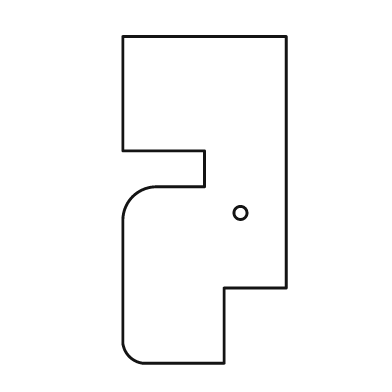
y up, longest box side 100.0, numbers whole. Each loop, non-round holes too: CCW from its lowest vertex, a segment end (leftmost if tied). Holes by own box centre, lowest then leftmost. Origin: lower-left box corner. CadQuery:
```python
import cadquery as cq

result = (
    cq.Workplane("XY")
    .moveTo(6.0, 0.0)
    .lineTo(31.0, 0.0)
    .lineTo(31.0, 23.0)
    .lineTo(50.0, 23.0)
    .lineTo(50.0, 100.0)
    .lineTo(0.0, 100.0)
    .lineTo(0.0, 65.0)
    .lineTo(25.0, 65.0)
    .lineTo(25.0, 54.0)
    .lineTo(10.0, 54.0)
    .threePointArc((3.0, 51.0), (0.0, 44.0))
    .lineTo(0.0, 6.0)
    .threePointArc((2.0, 2.0), (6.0, 0.0))
    .close()
    .moveTo(36.0, 46.0)
    .circle(2.0)
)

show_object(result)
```